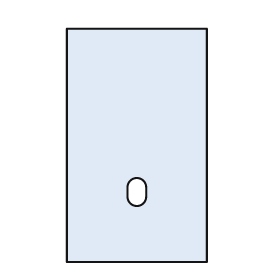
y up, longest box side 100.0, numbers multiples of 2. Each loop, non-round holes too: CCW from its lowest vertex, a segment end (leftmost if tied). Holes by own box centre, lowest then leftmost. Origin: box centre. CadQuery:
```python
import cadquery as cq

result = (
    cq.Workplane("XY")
    .moveTo(-30.0, -50.0)
    .lineTo(30.0, -50.0)
    .lineTo(30.0, 50.0)
    .lineTo(-30.0, 50.0)
    .close()
    .moveTo(-4.0, -22.0)
    .threePointArc((0.0, -26.0), (4.0, -22.0))
    .lineTo(4.0, -18.0)
    .threePointArc((0.0, -14.0), (-4.0, -18.0))
    .close()
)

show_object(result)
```